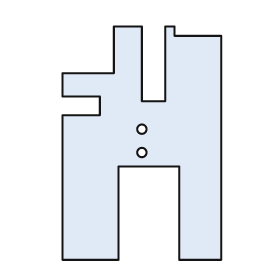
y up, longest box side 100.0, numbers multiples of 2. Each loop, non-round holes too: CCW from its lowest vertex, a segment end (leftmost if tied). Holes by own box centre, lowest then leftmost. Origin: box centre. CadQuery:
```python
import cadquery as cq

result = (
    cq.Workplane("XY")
    .moveTo(-34.0, -50.0)
    .lineTo(-10.0, -50.0)
    .lineTo(-10.0, -10.0)
    .lineTo(16.0, -10.0)
    .lineTo(16.0, -50.0)
    .lineTo(34.0, -50.0)
    .lineTo(34.0, 46.0)
    .lineTo(14.0, 46.0)
    .lineTo(14.0, 50.0)
    .lineTo(10.0, 50.0)
    .lineTo(10.0, 18.0)
    .lineTo(0.0, 18.0)
    .lineTo(0.0, 50.0)
    .lineTo(-12.0, 50.0)
    .lineTo(-12.0, 30.0)
    .lineTo(-34.0, 30.0)
    .lineTo(-34.0, 20.0)
    .lineTo(-18.0, 20.0)
    .lineTo(-18.0, 12.0)
    .lineTo(-34.0, 12.0)
    .close()
    .moveTo(0.0, -4.0)
    .circle(2.0)
    .moveTo(0.0, 6.0)
    .circle(2.0)
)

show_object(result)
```